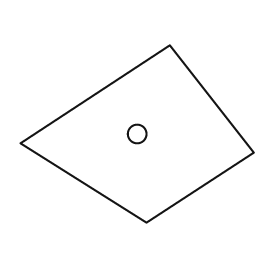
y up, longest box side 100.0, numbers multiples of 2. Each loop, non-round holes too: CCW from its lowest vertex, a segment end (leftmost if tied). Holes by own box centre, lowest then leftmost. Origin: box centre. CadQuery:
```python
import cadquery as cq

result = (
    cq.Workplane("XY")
    .moveTo(4.0, -38.0)
    .lineTo(50.0, -8.0)
    .lineTo(14.0, 38.0)
    .lineTo(-50.0, -4.0)
    .close()
    .moveTo(0.0, 0.0)
    .circle(4.0)
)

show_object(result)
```